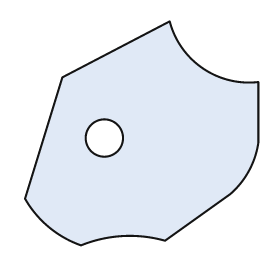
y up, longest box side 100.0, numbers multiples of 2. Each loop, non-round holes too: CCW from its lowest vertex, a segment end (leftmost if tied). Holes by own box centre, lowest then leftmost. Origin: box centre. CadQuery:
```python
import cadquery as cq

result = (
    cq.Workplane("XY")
    .moveTo(-26.0, -48.0)
    .threePointArc((-8.0, -44.0), (10.0, -46.0))
    .lineTo(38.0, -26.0)
    .threePointArc((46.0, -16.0), (50.0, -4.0))
    .lineTo(50.0, 22.0)
    .threePointArc((26.0, 28.0), (12.0, 48.0))
    .lineTo(-34.0, 24.0)
    .lineTo(-50.0, -28.0)
    .threePointArc((-40.0, -40.0), (-26.0, -48.0))
    .close()
    .moveTo(-16.0, -2.0)
    .circle(8.0)
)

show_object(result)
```